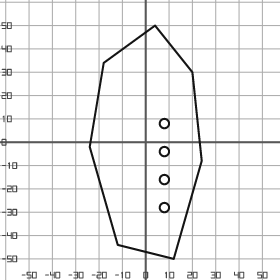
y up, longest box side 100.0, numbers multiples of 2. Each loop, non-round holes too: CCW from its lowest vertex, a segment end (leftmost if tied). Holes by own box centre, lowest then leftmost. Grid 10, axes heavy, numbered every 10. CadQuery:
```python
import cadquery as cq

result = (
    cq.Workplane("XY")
    .moveTo(12.0, -50.0)
    .lineTo(24.0, -8.0)
    .lineTo(20.0, 30.0)
    .lineTo(4.0, 50.0)
    .lineTo(-18.0, 34.0)
    .lineTo(-24.0, -2.0)
    .lineTo(-12.0, -44.0)
    .close()
    .moveTo(8.0, -28.0)
    .circle(2.0)
    .moveTo(8.0, -16.0)
    .circle(2.0)
    .moveTo(8.0, -4.0)
    .circle(2.0)
    .moveTo(8.0, 8.0)
    .circle(2.0)
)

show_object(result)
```